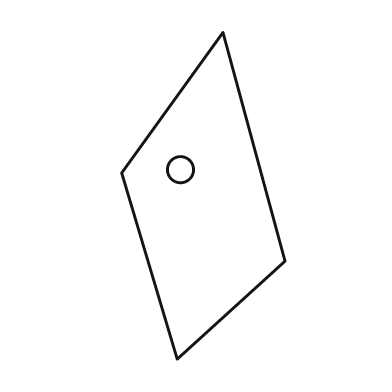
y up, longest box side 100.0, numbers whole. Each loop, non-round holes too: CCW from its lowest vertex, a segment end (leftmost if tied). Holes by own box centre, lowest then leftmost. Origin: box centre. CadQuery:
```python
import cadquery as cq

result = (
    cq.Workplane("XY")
    .moveTo(-8.0, -50.0)
    .lineTo(25.0, -20.0)
    .lineTo(6.0, 50.0)
    .lineTo(-25.0, 7.0)
    .close()
    .moveTo(-7.0, 8.0)
    .circle(4.0)
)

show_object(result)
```